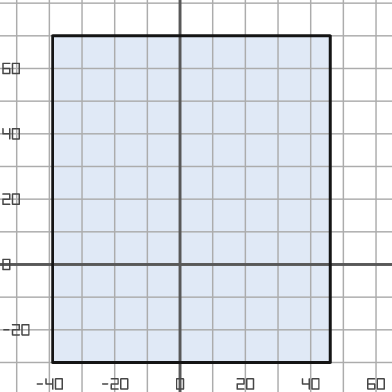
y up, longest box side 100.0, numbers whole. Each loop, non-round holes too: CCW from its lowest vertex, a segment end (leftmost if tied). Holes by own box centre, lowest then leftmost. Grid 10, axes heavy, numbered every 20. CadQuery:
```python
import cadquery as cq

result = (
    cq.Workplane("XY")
    .moveTo(-39.0, -30.0)
    .lineTo(46.0, -30.0)
    .lineTo(46.0, 70.0)
    .lineTo(-39.0, 70.0)
    .close()
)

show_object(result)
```